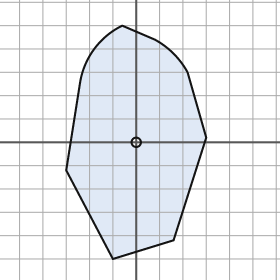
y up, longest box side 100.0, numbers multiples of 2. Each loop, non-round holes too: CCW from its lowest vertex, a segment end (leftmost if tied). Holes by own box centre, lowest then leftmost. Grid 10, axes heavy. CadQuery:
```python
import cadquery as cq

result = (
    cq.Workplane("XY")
    .moveTo(-10.0, -50.0)
    .lineTo(16.0, -42.0)
    .lineTo(30.0, 2.0)
    .lineTo(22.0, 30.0)
    .threePointArc((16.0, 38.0), (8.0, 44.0))
    .lineTo(-6.0, 50.0)
    .threePointArc((-18.0, 40.0), (-24.0, 26.0))
    .lineTo(-30.0, -12.0)
    .close()
    .moveTo(0.0, 0.0)
    .circle(2.0)
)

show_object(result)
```